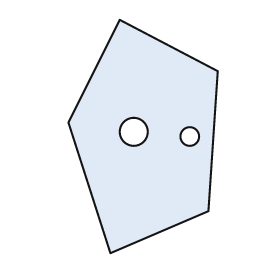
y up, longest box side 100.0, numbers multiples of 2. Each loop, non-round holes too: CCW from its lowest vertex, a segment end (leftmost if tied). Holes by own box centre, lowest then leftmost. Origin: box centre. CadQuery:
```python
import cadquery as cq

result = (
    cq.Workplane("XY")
    .moveTo(-14.0, -50.0)
    .lineTo(28.0, -32.0)
    .lineTo(32.0, 28.0)
    .lineTo(-10.0, 50.0)
    .lineTo(-32.0, 6.0)
    .close()
    .moveTo(20.0, 0.0)
    .circle(4.0)
    .moveTo(-4.0, 2.0)
    .circle(6.0)
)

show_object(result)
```